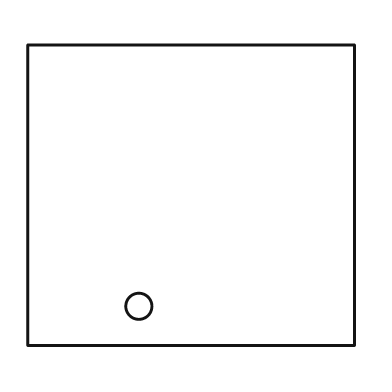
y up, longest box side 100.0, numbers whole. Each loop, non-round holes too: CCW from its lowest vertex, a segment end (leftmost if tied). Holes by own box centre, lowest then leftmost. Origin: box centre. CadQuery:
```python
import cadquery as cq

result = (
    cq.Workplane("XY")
    .moveTo(-50.0, -46.0)
    .lineTo(50.0, -46.0)
    .lineTo(50.0, 46.0)
    .lineTo(-50.0, 46.0)
    .close()
    .moveTo(-16.0, -34.0)
    .circle(4.0)
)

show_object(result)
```